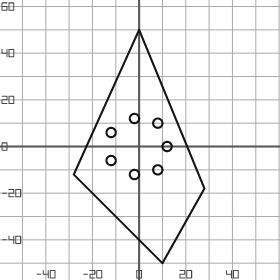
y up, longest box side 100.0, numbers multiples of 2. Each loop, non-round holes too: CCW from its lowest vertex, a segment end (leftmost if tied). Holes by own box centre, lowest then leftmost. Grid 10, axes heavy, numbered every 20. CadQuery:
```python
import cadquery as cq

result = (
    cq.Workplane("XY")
    .moveTo(10.0, -50.0)
    .lineTo(28.0, -18.0)
    .lineTo(0.0, 50.0)
    .lineTo(-28.0, -12.0)
    .close()
    .moveTo(-2.0, -12.0)
    .circle(2.0)
    .moveTo(8.0, -10.0)
    .circle(2.0)
    .moveTo(-12.0, -6.0)
    .circle(2.0)
    .moveTo(12.0, 0.0)
    .circle(2.0)
    .moveTo(-12.0, 6.0)
    .circle(2.0)
    .moveTo(8.0, 10.0)
    .circle(2.0)
    .moveTo(-2.0, 12.0)
    .circle(2.0)
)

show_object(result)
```